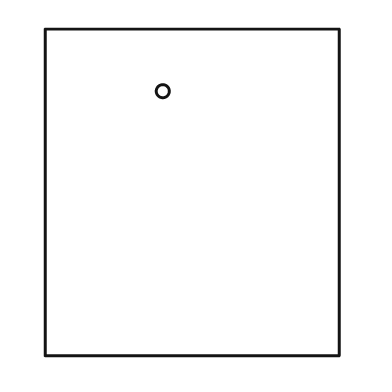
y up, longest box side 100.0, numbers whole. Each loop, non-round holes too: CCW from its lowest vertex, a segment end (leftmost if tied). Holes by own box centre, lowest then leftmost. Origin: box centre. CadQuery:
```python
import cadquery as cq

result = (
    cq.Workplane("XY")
    .moveTo(-45.0, -50.0)
    .lineTo(45.0, -50.0)
    .lineTo(45.0, 50.0)
    .lineTo(-45.0, 50.0)
    .close()
    .moveTo(-9.0, 31.0)
    .circle(2.0)
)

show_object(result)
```